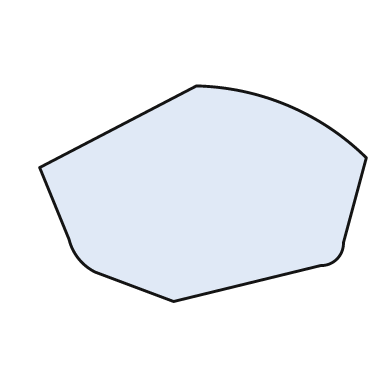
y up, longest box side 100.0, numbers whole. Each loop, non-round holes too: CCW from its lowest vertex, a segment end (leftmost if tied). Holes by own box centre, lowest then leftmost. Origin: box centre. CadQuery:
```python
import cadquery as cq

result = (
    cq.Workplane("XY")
    .moveTo(-9.0, -33.0)
    .lineTo(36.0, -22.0)
    .threePointArc((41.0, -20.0), (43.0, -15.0))
    .lineTo(50.0, 11.0)
    .threePointArc((26.0, 27.0), (-2.0, 33.0))
    .lineTo(-50.0, 8.0)
    .lineTo(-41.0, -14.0)
    .threePointArc((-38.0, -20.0), (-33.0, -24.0))
    .close()
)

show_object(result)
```